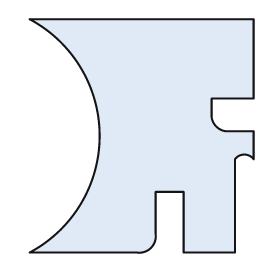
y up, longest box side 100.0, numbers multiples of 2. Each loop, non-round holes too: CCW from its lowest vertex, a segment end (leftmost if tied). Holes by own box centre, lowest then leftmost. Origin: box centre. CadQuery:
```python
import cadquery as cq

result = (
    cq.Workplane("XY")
    .moveTo(-48.0, -50.0)
    .lineTo(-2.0, -50.0)
    .threePointArc((4.0, -48.0), (6.0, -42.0))
    .lineTo(6.0, -24.0)
    .lineTo(18.0, -24.0)
    .lineTo(18.0, -50.0)
    .lineTo(40.0, -50.0)
    .lineTo(40.0, -10.0)
    .threePointArc((44.0, -8.0), (48.0, -10.0))
    .lineTo(48.0, 2.0)
    .lineTo(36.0, 2.0)
    .threePointArc((32.0, 4.0), (30.0, 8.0))
    .lineTo(30.0, 16.0)
    .lineTo(48.0, 16.0)
    .lineTo(48.0, 50.0)
    .lineTo(-48.0, 50.0)
    .threePointArc((-18.0, 0.0), (-48.0, -50.0))
    .close()
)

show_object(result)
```